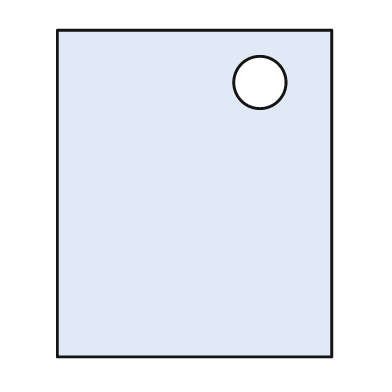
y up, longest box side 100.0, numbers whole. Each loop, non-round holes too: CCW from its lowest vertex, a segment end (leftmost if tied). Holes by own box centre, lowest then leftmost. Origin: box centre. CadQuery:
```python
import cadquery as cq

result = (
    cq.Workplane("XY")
    .moveTo(-42.0, -50.0)
    .lineTo(42.0, -50.0)
    .lineTo(42.0, 50.0)
    .lineTo(-42.0, 50.0)
    .close()
    .moveTo(20.0, 34.0)
    .circle(8.0)
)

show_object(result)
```